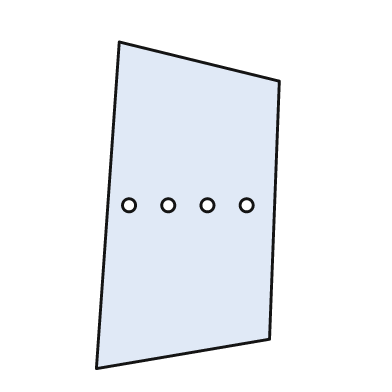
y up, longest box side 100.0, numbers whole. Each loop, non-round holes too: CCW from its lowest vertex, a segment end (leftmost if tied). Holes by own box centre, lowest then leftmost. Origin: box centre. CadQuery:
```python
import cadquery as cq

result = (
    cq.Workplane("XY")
    .moveTo(-28.0, -50.0)
    .lineTo(25.0, -41.0)
    .lineTo(28.0, 38.0)
    .lineTo(-21.0, 50.0)
    .close()
    .moveTo(-18.0, 0.0)
    .circle(2.0)
    .moveTo(-6.0, 0.0)
    .circle(2.0)
    .moveTo(6.0, 0.0)
    .circle(2.0)
    .moveTo(18.0, 0.0)
    .circle(2.0)
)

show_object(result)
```